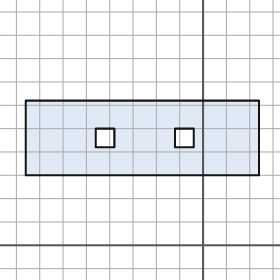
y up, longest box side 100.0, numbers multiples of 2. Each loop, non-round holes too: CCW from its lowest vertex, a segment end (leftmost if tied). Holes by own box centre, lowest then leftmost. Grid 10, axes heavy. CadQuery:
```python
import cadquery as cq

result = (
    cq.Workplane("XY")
    .moveTo(-76.0, 30.0)
    .lineTo(24.0, 30.0)
    .lineTo(24.0, 62.0)
    .lineTo(-76.0, 62.0)
    .close()
    .moveTo(-46.0, 42.0)
    .lineTo(-38.0, 42.0)
    .lineTo(-38.0, 50.0)
    .lineTo(-46.0, 50.0)
    .close()
    .moveTo(-12.0, 42.0)
    .lineTo(-4.0, 42.0)
    .lineTo(-4.0, 50.0)
    .lineTo(-12.0, 50.0)
    .close()
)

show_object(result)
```